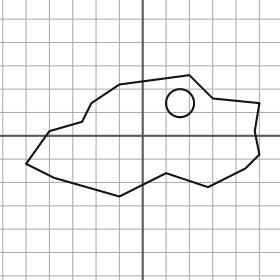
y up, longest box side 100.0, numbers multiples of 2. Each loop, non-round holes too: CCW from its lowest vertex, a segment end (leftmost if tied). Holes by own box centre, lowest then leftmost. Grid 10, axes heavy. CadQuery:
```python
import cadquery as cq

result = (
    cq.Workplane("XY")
    .moveTo(-10.0, -26.0)
    .lineTo(10.0, -16.0)
    .lineTo(28.0, -22.0)
    .lineTo(44.0, -14.0)
    .lineTo(50.0, -8.0)
    .lineTo(48.0, 2.0)
    .lineTo(50.0, 14.0)
    .lineTo(30.0, 16.0)
    .lineTo(20.0, 26.0)
    .lineTo(-10.0, 22.0)
    .lineTo(-22.0, 14.0)
    .lineTo(-26.0, 6.0)
    .lineTo(-40.0, 2.0)
    .lineTo(-50.0, -12.0)
    .lineTo(-38.0, -18.0)
    .close()
    .moveTo(16.0, 14.0)
    .circle(6.0)
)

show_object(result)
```